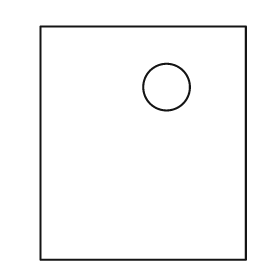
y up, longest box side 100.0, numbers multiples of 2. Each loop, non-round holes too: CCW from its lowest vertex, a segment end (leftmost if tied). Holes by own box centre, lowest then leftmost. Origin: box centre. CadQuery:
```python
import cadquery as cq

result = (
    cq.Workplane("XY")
    .moveTo(-44.0, -50.0)
    .lineTo(44.0, -50.0)
    .lineTo(44.0, 50.0)
    .lineTo(-44.0, 50.0)
    .close()
    .moveTo(10.0, 24.0)
    .circle(10.0)
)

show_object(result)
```